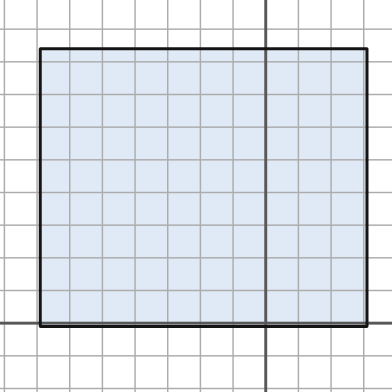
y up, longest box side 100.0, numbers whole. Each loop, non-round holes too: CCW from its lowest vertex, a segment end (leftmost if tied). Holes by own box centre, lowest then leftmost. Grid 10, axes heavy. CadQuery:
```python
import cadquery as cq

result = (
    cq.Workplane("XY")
    .moveTo(-69.0, -1.0)
    .lineTo(31.0, -1.0)
    .lineTo(31.0, 84.0)
    .lineTo(-69.0, 84.0)
    .close()
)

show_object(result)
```